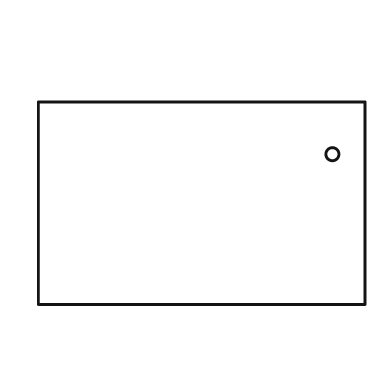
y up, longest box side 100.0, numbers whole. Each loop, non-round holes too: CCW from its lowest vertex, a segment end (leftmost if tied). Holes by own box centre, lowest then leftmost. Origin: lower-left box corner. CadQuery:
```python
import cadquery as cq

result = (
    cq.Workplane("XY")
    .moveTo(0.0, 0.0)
    .lineTo(100.0, 0.0)
    .lineTo(100.0, 62.0)
    .lineTo(0.0, 62.0)
    .close()
    .moveTo(90.0, 46.0)
    .circle(2.0)
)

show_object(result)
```